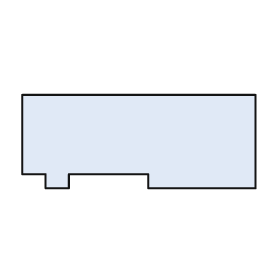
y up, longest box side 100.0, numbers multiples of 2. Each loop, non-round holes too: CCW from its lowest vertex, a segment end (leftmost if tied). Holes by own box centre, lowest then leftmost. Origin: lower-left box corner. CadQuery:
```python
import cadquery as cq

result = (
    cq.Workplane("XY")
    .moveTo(10.0, 0.0)
    .lineTo(20.0, 0.0)
    .lineTo(20.0, 6.0)
    .lineTo(54.0, 6.0)
    .lineTo(54.0, 0.0)
    .lineTo(100.0, 0.0)
    .lineTo(100.0, 40.0)
    .lineTo(0.0, 40.0)
    .lineTo(0.0, 6.0)
    .lineTo(10.0, 6.0)
    .close()
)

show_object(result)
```